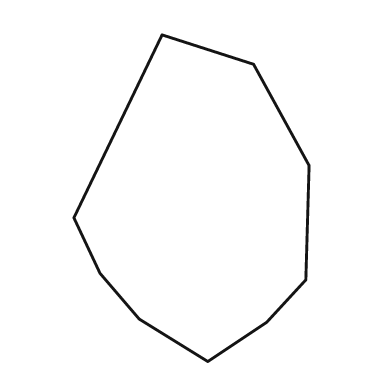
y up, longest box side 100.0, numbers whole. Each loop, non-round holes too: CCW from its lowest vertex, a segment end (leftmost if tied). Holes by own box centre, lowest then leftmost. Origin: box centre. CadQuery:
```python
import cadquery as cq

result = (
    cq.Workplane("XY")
    .moveTo(5.0, -50.0)
    .lineTo(23.0, -38.0)
    .lineTo(35.0, -25.0)
    .lineTo(36.0, 10.0)
    .lineTo(19.0, 41.0)
    .lineTo(-9.0, 50.0)
    .lineTo(-36.0, -6.0)
    .lineTo(-28.0, -23.0)
    .lineTo(-16.0, -37.0)
    .close()
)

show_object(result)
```